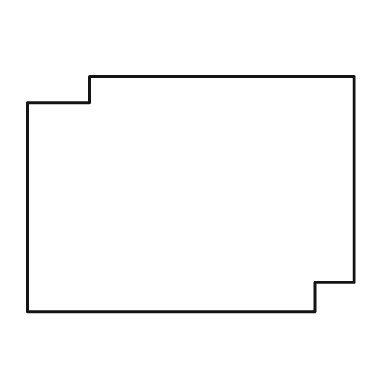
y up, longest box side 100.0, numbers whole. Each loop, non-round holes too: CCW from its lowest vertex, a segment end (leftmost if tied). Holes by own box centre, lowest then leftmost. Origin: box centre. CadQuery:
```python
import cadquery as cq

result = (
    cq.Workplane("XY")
    .moveTo(-50.0, -36.0)
    .lineTo(38.0, -36.0)
    .lineTo(38.0, -27.0)
    .lineTo(50.0, -27.0)
    .lineTo(50.0, 36.0)
    .lineTo(-31.0, 36.0)
    .lineTo(-31.0, 28.0)
    .lineTo(-50.0, 28.0)
    .close()
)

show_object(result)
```